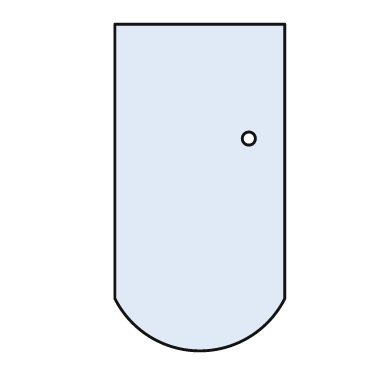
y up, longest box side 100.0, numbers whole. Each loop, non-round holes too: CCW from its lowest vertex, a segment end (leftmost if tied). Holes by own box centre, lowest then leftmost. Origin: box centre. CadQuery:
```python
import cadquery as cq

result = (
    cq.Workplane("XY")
    .moveTo(-26.0, -34.0)
    .threePointArc((0.0, -50.0), (26.0, -34.0))
    .lineTo(26.0, 50.0)
    .lineTo(-26.0, 50.0)
    .close()
    .moveTo(15.0, 15.0)
    .circle(2.0)
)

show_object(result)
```